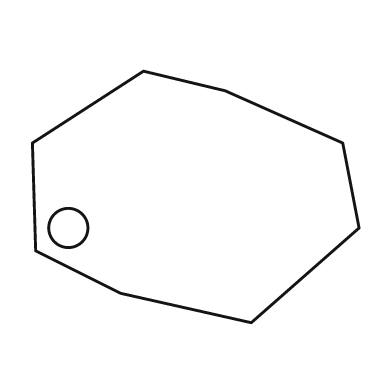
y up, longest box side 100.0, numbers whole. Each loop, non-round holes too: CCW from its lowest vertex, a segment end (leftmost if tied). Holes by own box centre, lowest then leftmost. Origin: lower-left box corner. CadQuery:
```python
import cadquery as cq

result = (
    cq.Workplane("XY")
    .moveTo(67.0, 0.0)
    .lineTo(100.0, 29.0)
    .lineTo(95.0, 55.0)
    .lineTo(59.0, 71.0)
    .lineTo(34.0, 77.0)
    .lineTo(0.0, 55.0)
    .lineTo(1.0, 22.0)
    .lineTo(27.0, 9.0)
    .close()
    .moveTo(11.0, 29.0)
    .circle(6.0)
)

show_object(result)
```